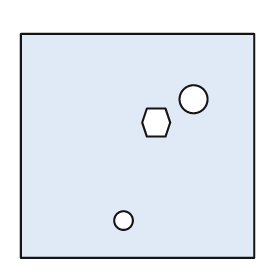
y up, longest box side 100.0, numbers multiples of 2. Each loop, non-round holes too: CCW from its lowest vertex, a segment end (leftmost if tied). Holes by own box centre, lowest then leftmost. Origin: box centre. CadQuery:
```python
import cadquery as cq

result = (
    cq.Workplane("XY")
    .moveTo(-50.0, -48.0)
    .lineTo(50.0, -48.0)
    .lineTo(50.0, 48.0)
    .lineTo(-50.0, 48.0)
    .close()
    .moveTo(-6.0, -32.0)
    .circle(4.0)
    .moveTo(4.0, 4.0)
    .lineTo(12.0, 4.0)
    .lineTo(14.0, 10.0)
    .lineTo(12.0, 16.0)
    .lineTo(4.0, 16.0)
    .lineTo(2.0, 10.0)
    .close()
    .moveTo(24.0, 20.0)
    .circle(6.0)
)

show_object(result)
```